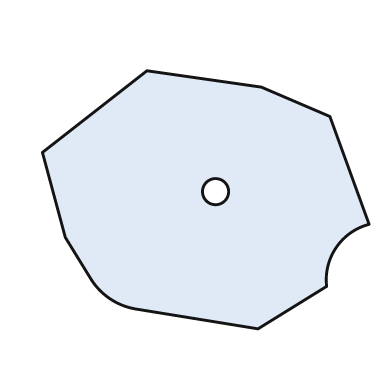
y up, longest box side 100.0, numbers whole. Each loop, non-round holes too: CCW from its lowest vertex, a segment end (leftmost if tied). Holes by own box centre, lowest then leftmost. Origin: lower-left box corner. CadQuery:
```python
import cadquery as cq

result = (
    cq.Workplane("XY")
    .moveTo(66.0, 0.0)
    .lineTo(87.0, 13.0)
    .threePointArc((90.0, 25.0), (100.0, 32.0))
    .lineTo(88.0, 65.0)
    .lineTo(67.0, 74.0)
    .lineTo(32.0, 79.0)
    .lineTo(0.0, 54.0)
    .lineTo(7.0, 28.0)
    .lineTo(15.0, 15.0)
    .threePointArc((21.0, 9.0), (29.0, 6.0))
    .close()
    .moveTo(53.0, 42.0)
    .circle(4.0)
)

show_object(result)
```